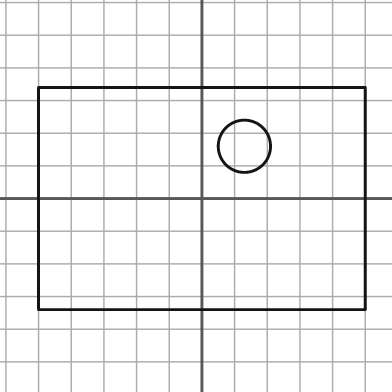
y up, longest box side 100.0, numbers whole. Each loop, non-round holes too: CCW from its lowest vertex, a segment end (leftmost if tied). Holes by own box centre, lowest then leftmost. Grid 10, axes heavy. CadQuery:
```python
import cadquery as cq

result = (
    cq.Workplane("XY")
    .moveTo(-50.0, -34.0)
    .lineTo(50.0, -34.0)
    .lineTo(50.0, 34.0)
    .lineTo(-50.0, 34.0)
    .close()
    .moveTo(13.0, 16.0)
    .circle(8.0)
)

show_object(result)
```